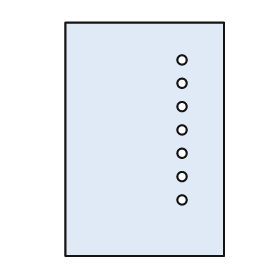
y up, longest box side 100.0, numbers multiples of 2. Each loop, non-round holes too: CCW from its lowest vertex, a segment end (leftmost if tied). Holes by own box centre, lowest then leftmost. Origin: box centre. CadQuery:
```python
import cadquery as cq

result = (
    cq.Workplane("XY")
    .moveTo(-34.0, -50.0)
    .lineTo(34.0, -50.0)
    .lineTo(34.0, 50.0)
    .lineTo(-34.0, 50.0)
    .close()
    .moveTo(16.0, -26.0)
    .circle(2.0)
    .moveTo(16.0, -16.0)
    .circle(2.0)
    .moveTo(16.0, -6.0)
    .circle(2.0)
    .moveTo(16.0, 4.0)
    .circle(2.0)
    .moveTo(16.0, 14.0)
    .circle(2.0)
    .moveTo(16.0, 24.0)
    .circle(2.0)
    .moveTo(16.0, 34.0)
    .circle(2.0)
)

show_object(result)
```